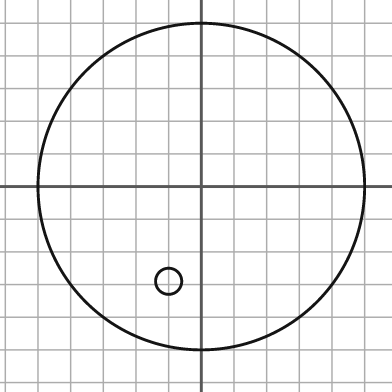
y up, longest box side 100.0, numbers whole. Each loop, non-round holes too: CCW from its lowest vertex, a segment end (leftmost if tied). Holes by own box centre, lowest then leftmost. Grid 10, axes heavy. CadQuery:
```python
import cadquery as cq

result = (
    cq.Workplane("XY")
    .moveTo(0.0, 0.0)
    .circle(50.0)
    .moveTo(-10.0, -29.0)
    .circle(4.0)
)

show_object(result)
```